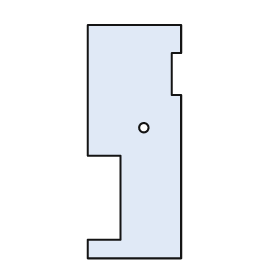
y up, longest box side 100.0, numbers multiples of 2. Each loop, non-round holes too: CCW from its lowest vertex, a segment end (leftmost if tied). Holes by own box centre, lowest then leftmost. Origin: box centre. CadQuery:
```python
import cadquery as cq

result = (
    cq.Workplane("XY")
    .moveTo(-20.0, -50.0)
    .lineTo(20.0, -50.0)
    .lineTo(20.0, 20.0)
    .lineTo(16.0, 20.0)
    .lineTo(16.0, 38.0)
    .lineTo(20.0, 38.0)
    .lineTo(20.0, 50.0)
    .lineTo(-20.0, 50.0)
    .lineTo(-20.0, -6.0)
    .lineTo(-6.0, -6.0)
    .lineTo(-6.0, -42.0)
    .lineTo(-20.0, -42.0)
    .close()
    .moveTo(4.0, 6.0)
    .circle(2.0)
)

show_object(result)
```